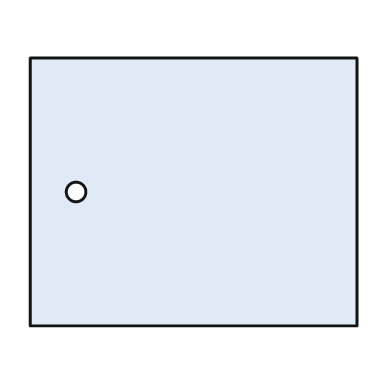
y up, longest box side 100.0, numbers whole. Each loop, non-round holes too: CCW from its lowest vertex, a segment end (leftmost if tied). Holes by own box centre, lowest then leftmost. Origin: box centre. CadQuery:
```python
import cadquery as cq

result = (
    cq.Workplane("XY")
    .moveTo(-50.0, -41.0)
    .lineTo(50.0, -41.0)
    .lineTo(50.0, 41.0)
    .lineTo(-50.0, 41.0)
    .close()
    .moveTo(-36.0, 0.0)
    .circle(3.0)
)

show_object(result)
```